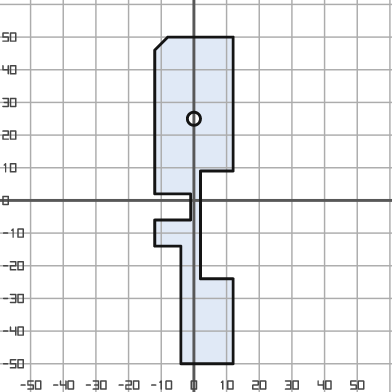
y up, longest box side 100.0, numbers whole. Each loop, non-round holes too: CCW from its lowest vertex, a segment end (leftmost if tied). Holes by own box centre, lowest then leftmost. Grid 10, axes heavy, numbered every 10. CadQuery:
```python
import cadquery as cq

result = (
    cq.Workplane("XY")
    .moveTo(-4.0, -50.0)
    .lineTo(12.0, -50.0)
    .lineTo(12.0, -24.0)
    .lineTo(2.0, -24.0)
    .lineTo(2.0, 9.0)
    .lineTo(12.0, 9.0)
    .lineTo(12.0, 50.0)
    .lineTo(-8.0, 50.0)
    .lineTo(-12.0, 46.0)
    .lineTo(-12.0, 2.0)
    .lineTo(-1.0, 2.0)
    .lineTo(-1.0, -6.0)
    .lineTo(-12.0, -6.0)
    .lineTo(-12.0, -14.0)
    .lineTo(-4.0, -14.0)
    .close()
    .moveTo(0.0, 25.0)
    .circle(2.0)
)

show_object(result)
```